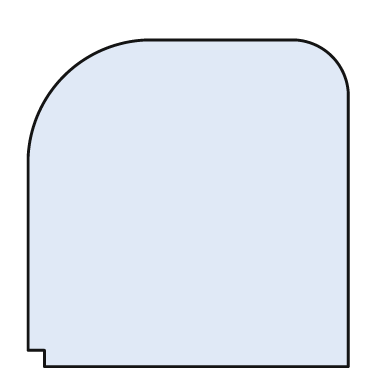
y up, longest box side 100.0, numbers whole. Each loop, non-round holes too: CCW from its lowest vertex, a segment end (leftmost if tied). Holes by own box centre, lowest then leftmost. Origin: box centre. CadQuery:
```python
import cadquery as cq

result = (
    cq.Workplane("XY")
    .moveTo(-44.0, -50.0)
    .lineTo(49.0, -50.0)
    .lineTo(49.0, 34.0)
    .threePointArc((44.0, 45.0), (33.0, 50.0))
    .lineTo(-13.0, 50.0)
    .threePointArc((-38.0, 39.0), (-49.0, 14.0))
    .lineTo(-49.0, -45.0)
    .lineTo(-44.0, -45.0)
    .close()
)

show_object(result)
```